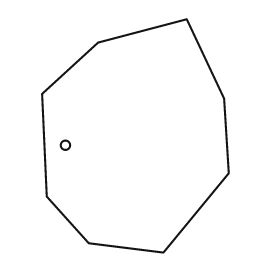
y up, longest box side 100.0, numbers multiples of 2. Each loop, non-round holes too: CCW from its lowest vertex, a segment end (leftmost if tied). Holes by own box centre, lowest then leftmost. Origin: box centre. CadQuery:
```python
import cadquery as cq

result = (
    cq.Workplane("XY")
    .moveTo(12.0, -50.0)
    .lineTo(40.0, -16.0)
    .lineTo(38.0, 16.0)
    .lineTo(22.0, 50.0)
    .lineTo(-16.0, 40.0)
    .lineTo(-40.0, 18.0)
    .lineTo(-38.0, -26.0)
    .lineTo(-20.0, -46.0)
    .close()
    .moveTo(-30.0, -4.0)
    .circle(2.0)
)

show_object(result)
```